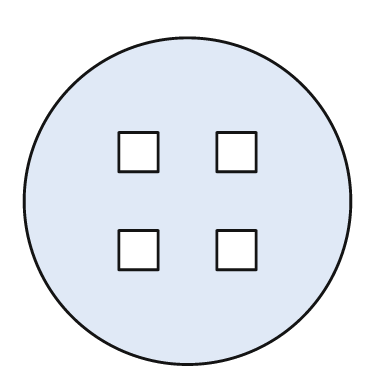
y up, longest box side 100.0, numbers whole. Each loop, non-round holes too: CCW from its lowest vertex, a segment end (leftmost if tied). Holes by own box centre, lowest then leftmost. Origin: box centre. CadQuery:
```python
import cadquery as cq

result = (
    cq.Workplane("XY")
    .moveTo(0.0, 0.0)
    .circle(50.0)
    .moveTo(-21.0, -21.0)
    .lineTo(-9.0, -21.0)
    .lineTo(-9.0, -9.0)
    .lineTo(-21.0, -9.0)
    .close()
    .moveTo(9.0, -21.0)
    .lineTo(21.0, -21.0)
    .lineTo(21.0, -9.0)
    .lineTo(9.0, -9.0)
    .close()
    .moveTo(-21.0, 9.0)
    .lineTo(-9.0, 9.0)
    .lineTo(-9.0, 21.0)
    .lineTo(-21.0, 21.0)
    .close()
    .moveTo(9.0, 9.0)
    .lineTo(21.0, 9.0)
    .lineTo(21.0, 21.0)
    .lineTo(9.0, 21.0)
    .close()
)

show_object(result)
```